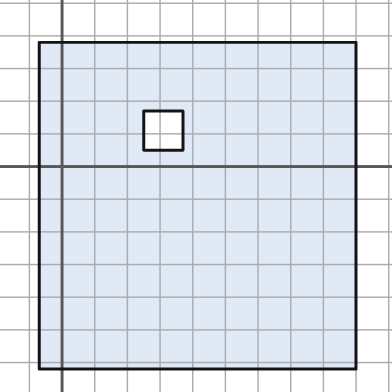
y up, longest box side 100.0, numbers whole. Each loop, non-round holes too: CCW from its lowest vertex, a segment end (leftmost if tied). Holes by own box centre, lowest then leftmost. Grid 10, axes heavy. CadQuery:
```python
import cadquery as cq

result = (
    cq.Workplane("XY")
    .moveTo(-7.0, -62.0)
    .lineTo(90.0, -62.0)
    .lineTo(90.0, 38.0)
    .lineTo(-7.0, 38.0)
    .close()
    .moveTo(25.0, 5.0)
    .lineTo(37.0, 5.0)
    .lineTo(37.0, 17.0)
    .lineTo(25.0, 17.0)
    .close()
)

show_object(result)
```